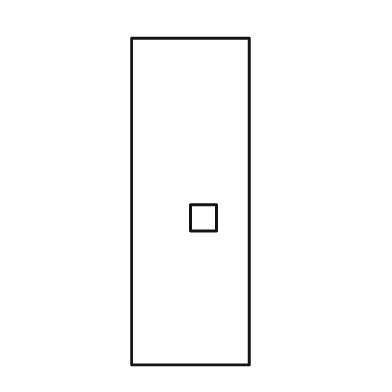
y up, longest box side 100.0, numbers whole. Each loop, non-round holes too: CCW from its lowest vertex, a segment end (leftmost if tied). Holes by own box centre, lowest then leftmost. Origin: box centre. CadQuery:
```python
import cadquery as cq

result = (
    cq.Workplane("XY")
    .moveTo(-18.0, -50.0)
    .lineTo(18.0, -50.0)
    .lineTo(18.0, 50.0)
    .lineTo(-18.0, 50.0)
    .close()
    .moveTo(0.0, -9.0)
    .lineTo(8.0, -9.0)
    .lineTo(8.0, -1.0)
    .lineTo(0.0, -1.0)
    .close()
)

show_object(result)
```